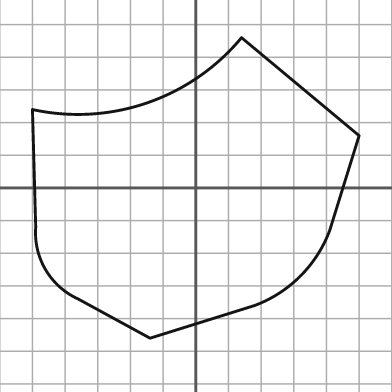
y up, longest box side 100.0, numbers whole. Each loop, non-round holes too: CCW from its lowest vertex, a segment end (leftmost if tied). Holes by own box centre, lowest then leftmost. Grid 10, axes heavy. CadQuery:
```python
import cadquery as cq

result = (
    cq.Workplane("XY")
    .moveTo(-14.0, -46.0)
    .lineTo(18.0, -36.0)
    .threePointArc((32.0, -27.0), (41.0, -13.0))
    .lineTo(50.0, 16.0)
    .lineTo(14.0, 46.0)
    .threePointArc((-15.0, 26.0), (-50.0, 24.0))
    .lineTo(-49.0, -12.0)
    .threePointArc((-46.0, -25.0), (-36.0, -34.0))
    .close()
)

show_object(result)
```